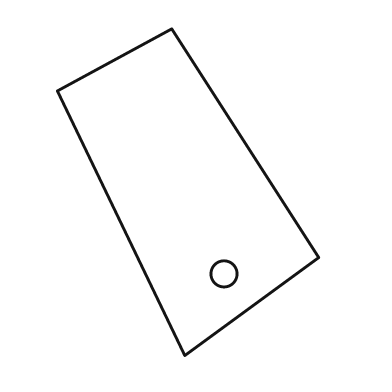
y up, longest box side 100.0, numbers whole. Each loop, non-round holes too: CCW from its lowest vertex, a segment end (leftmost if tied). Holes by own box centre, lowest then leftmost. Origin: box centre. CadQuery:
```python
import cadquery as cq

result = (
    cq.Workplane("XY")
    .moveTo(-1.0, -50.0)
    .lineTo(40.0, -20.0)
    .lineTo(-5.0, 50.0)
    .lineTo(-40.0, 31.0)
    .close()
    .moveTo(11.0, -25.0)
    .circle(4.0)
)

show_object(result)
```